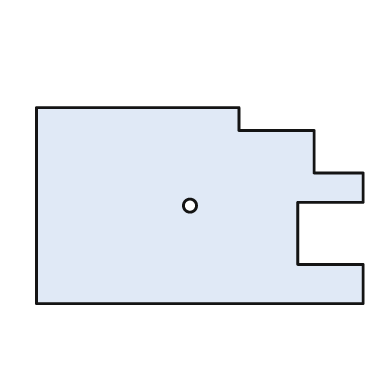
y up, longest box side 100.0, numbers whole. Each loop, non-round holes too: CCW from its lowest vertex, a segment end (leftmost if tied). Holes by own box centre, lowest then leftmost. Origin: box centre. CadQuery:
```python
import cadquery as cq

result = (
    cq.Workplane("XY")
    .moveTo(-50.0, -30.0)
    .lineTo(50.0, -30.0)
    .lineTo(50.0, -18.0)
    .lineTo(30.0, -18.0)
    .lineTo(30.0, 1.0)
    .lineTo(50.0, 1.0)
    .lineTo(50.0, 10.0)
    .lineTo(35.0, 10.0)
    .lineTo(35.0, 23.0)
    .lineTo(12.0, 23.0)
    .lineTo(12.0, 30.0)
    .lineTo(-50.0, 30.0)
    .close()
    .moveTo(-3.0, 0.0)
    .circle(2.0)
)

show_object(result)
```